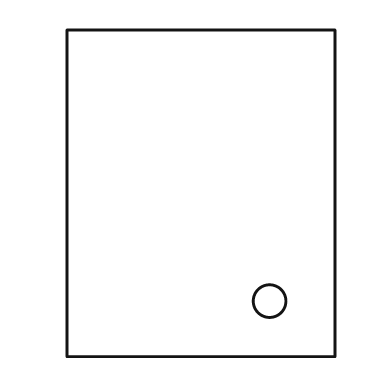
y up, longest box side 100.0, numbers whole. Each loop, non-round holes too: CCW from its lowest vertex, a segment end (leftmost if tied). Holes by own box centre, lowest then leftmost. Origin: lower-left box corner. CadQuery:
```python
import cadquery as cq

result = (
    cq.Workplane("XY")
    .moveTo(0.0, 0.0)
    .lineTo(82.0, 0.0)
    .lineTo(82.0, 100.0)
    .lineTo(0.0, 100.0)
    .close()
    .moveTo(62.0, 17.0)
    .circle(5.0)
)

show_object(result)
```